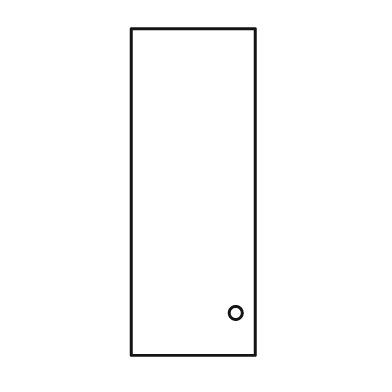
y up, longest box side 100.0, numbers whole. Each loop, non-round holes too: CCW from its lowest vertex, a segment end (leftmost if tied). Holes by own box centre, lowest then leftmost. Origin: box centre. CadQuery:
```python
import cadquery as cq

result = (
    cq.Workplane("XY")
    .moveTo(-19.0, -50.0)
    .lineTo(19.0, -50.0)
    .lineTo(19.0, 50.0)
    .lineTo(-19.0, 50.0)
    .close()
    .moveTo(13.0, -37.0)
    .circle(2.0)
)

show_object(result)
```